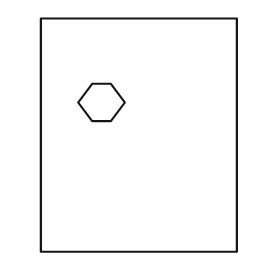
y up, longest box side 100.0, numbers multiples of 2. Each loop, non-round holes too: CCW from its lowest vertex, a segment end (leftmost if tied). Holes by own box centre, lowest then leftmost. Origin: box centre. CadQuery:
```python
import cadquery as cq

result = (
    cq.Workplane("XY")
    .moveTo(-42.0, -50.0)
    .lineTo(42.0, -50.0)
    .lineTo(42.0, 50.0)
    .lineTo(-42.0, 50.0)
    .close()
    .moveTo(-20.0, 6.0)
    .lineTo(-12.0, 6.0)
    .lineTo(-6.0, 14.0)
    .lineTo(-12.0, 22.0)
    .lineTo(-20.0, 22.0)
    .lineTo(-26.0, 14.0)
    .close()
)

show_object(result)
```